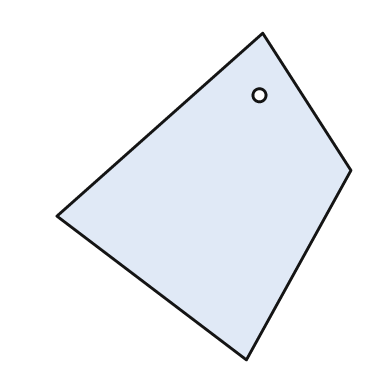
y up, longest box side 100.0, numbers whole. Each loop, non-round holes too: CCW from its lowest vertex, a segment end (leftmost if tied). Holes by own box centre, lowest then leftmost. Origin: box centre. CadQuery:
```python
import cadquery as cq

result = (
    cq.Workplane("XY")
    .moveTo(13.0, -50.0)
    .lineTo(45.0, 8.0)
    .lineTo(18.0, 50.0)
    .lineTo(-45.0, -6.0)
    .close()
    .moveTo(17.0, 31.0)
    .circle(2.0)
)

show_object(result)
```